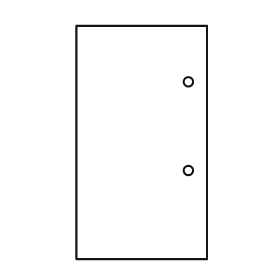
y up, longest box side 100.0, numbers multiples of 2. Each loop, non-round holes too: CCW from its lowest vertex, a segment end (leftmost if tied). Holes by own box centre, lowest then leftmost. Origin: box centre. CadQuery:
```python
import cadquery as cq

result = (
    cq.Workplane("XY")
    .moveTo(-28.0, -50.0)
    .lineTo(28.0, -50.0)
    .lineTo(28.0, 50.0)
    .lineTo(-28.0, 50.0)
    .close()
    .moveTo(20.0, -12.0)
    .circle(2.0)
    .moveTo(20.0, 26.0)
    .circle(2.0)
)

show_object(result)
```